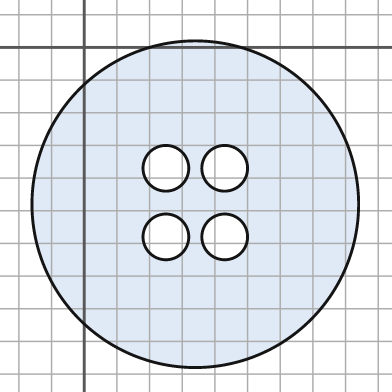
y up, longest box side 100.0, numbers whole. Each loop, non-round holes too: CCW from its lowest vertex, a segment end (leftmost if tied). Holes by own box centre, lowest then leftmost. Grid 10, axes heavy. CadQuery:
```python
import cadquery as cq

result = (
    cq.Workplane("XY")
    .moveTo(34.0, -48.0)
    .circle(50.0)
    .moveTo(25.0, -58.0)
    .circle(7.0)
    .moveTo(43.0, -58.0)
    .circle(7.0)
    .moveTo(25.0, -37.0)
    .circle(7.0)
    .moveTo(43.0, -37.0)
    .circle(7.0)
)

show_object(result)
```